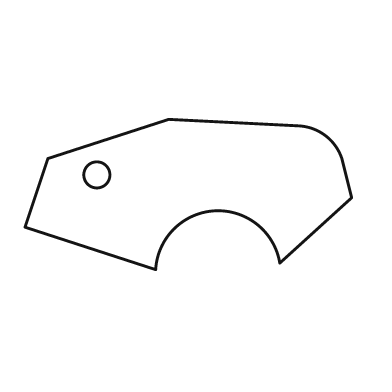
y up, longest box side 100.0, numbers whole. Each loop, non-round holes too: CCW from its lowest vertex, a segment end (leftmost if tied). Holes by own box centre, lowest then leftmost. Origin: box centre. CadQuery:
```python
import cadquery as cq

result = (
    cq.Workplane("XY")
    .moveTo(-10.0, -23.0)
    .threePointArc((8.0, -5.0), (28.0, -21.0))
    .lineTo(50.0, -1.0)
    .lineTo(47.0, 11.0)
    .threePointArc((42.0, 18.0), (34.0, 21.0))
    .lineTo(-6.0, 23.0)
    .lineTo(-43.0, 11.0)
    .lineTo(-50.0, -10.0)
    .close()
    .moveTo(-28.0, 6.0)
    .circle(4.0)
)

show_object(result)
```